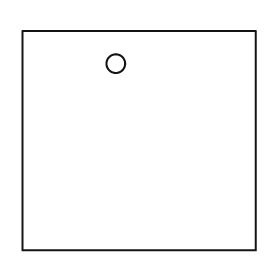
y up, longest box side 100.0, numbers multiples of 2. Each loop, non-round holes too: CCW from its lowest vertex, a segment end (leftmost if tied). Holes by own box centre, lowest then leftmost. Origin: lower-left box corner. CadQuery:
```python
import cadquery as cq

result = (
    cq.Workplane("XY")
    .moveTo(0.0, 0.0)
    .lineTo(100.0, 0.0)
    .lineTo(100.0, 94.0)
    .lineTo(0.0, 94.0)
    .close()
    .moveTo(40.0, 80.0)
    .circle(4.0)
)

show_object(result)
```